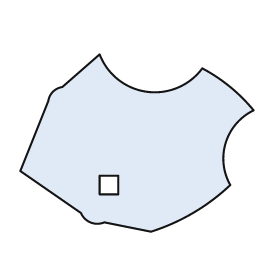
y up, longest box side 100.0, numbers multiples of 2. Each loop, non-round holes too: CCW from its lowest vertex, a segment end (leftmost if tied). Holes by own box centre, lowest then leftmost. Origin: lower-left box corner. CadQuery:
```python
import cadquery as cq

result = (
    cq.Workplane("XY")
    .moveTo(56.0, 0.0)
    .threePointArc((74.0, 8.0), (90.0, 20.0))
    .threePointArc((88.0, 38.0), (100.0, 52.0))
    .threePointArc((90.0, 62.0), (78.0, 70.0))
    .threePointArc((54.0, 60.0), (34.0, 76.0))
    .lineTo(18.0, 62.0)
    .threePointArc((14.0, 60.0), (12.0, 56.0))
    .lineTo(0.0, 26.0)
    .lineTo(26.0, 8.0)
    .threePointArc((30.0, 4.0), (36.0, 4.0))
    .close()
    .moveTo(34.0, 16.0)
    .lineTo(42.0, 16.0)
    .lineTo(42.0, 24.0)
    .lineTo(34.0, 24.0)
    .close()
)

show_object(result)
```